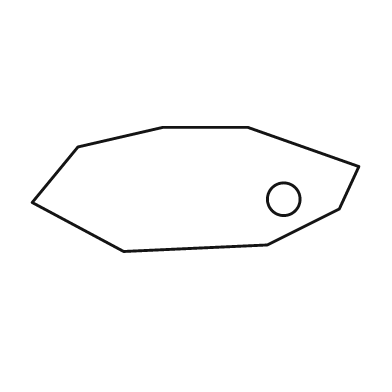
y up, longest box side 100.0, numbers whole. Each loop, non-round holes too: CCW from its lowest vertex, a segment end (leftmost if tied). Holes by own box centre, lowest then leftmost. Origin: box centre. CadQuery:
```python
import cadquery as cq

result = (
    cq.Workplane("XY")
    .moveTo(-22.0, -19.0)
    .lineTo(22.0, -17.0)
    .lineTo(44.0, -6.0)
    .lineTo(50.0, 7.0)
    .lineTo(16.0, 19.0)
    .lineTo(-10.0, 19.0)
    .lineTo(-36.0, 13.0)
    .lineTo(-50.0, -4.0)
    .close()
    .moveTo(27.0, -3.0)
    .circle(5.0)
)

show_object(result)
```